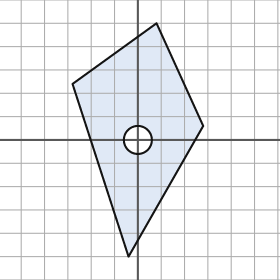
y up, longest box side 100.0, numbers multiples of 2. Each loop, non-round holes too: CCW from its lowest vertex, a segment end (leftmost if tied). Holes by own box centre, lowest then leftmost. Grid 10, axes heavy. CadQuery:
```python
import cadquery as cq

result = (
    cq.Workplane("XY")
    .moveTo(-4.0, -50.0)
    .lineTo(28.0, 6.0)
    .lineTo(8.0, 50.0)
    .lineTo(-28.0, 24.0)
    .close()
    .moveTo(0.0, 0.0)
    .circle(6.0)
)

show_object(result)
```